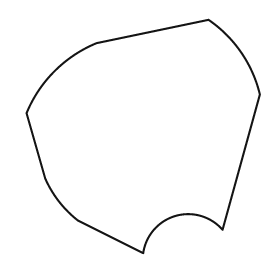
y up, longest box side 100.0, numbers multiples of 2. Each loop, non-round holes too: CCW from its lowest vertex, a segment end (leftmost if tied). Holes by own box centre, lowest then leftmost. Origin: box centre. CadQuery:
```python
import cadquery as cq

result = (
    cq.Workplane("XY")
    .moveTo(0.0, -50.0)
    .threePointArc((14.0, -34.0), (34.0, -40.0))
    .lineTo(50.0, 18.0)
    .threePointArc((42.0, 36.0), (28.0, 50.0))
    .lineTo(-20.0, 40.0)
    .threePointArc((-38.0, 28.0), (-50.0, 10.0))
    .lineTo(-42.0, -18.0)
    .threePointArc((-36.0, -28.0), (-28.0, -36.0))
    .close()
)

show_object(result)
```